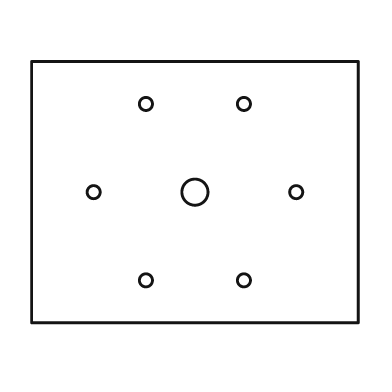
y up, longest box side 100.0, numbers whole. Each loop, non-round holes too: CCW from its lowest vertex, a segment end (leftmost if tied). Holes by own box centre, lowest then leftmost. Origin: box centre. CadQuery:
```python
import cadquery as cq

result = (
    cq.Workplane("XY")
    .moveTo(-50.0, -40.0)
    .lineTo(50.0, -40.0)
    .lineTo(50.0, 40.0)
    .lineTo(-50.0, 40.0)
    .close()
    .moveTo(-15.0, -27.0)
    .circle(2.0)
    .moveTo(15.0, -27.0)
    .circle(2.0)
    .moveTo(-31.0, 0.0)
    .circle(2.0)
    .moveTo(0.0, 0.0)
    .circle(4.0)
    .moveTo(31.0, 0.0)
    .circle(2.0)
    .moveTo(-15.0, 27.0)
    .circle(2.0)
    .moveTo(15.0, 27.0)
    .circle(2.0)
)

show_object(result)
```